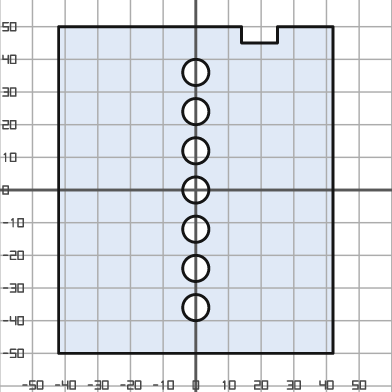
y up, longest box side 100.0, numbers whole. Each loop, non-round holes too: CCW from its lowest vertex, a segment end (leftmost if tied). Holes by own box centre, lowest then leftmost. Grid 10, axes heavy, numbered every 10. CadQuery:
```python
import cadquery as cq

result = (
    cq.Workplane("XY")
    .moveTo(-42.0, -50.0)
    .lineTo(42.0, -50.0)
    .lineTo(42.0, 50.0)
    .lineTo(25.0, 50.0)
    .lineTo(25.0, 45.0)
    .lineTo(14.0, 45.0)
    .lineTo(14.0, 50.0)
    .lineTo(-42.0, 50.0)
    .close()
    .moveTo(0.0, -36.0)
    .circle(4.0)
    .moveTo(0.0, -24.0)
    .circle(4.0)
    .moveTo(0.0, -12.0)
    .circle(4.0)
    .moveTo(0.0, 0.0)
    .circle(4.0)
    .moveTo(0.0, 12.0)
    .circle(4.0)
    .moveTo(0.0, 24.0)
    .circle(4.0)
    .moveTo(0.0, 36.0)
    .circle(4.0)
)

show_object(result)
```